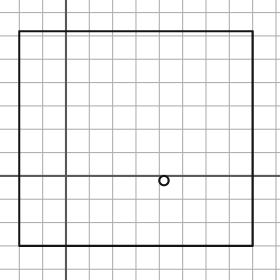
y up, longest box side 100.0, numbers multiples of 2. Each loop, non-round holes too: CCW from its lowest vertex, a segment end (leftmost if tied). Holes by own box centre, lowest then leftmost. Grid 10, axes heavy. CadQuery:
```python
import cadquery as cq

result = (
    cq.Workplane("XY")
    .moveTo(-20.0, -30.0)
    .lineTo(80.0, -30.0)
    .lineTo(80.0, 62.0)
    .lineTo(-20.0, 62.0)
    .close()
    .moveTo(42.0, -2.0)
    .circle(2.0)
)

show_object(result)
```